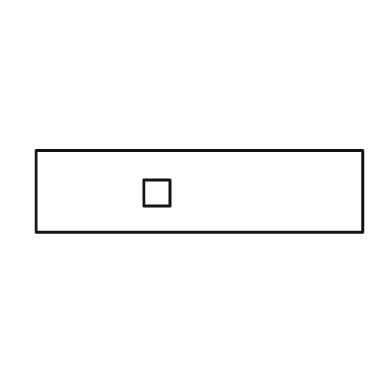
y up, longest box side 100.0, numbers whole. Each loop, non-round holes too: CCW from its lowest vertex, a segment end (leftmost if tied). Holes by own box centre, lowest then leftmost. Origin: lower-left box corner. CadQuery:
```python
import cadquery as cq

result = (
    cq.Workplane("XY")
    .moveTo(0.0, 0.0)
    .lineTo(100.0, 0.0)
    .lineTo(100.0, 25.0)
    .lineTo(0.0, 25.0)
    .close()
    .moveTo(33.0, 8.0)
    .lineTo(41.0, 8.0)
    .lineTo(41.0, 16.0)
    .lineTo(33.0, 16.0)
    .close()
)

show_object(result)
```